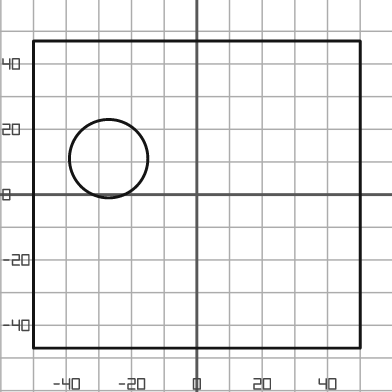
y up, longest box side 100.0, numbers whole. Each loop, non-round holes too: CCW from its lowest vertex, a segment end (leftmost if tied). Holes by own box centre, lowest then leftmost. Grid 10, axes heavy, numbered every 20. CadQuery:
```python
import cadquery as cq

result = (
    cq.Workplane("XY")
    .moveTo(-50.0, -47.0)
    .lineTo(50.0, -47.0)
    .lineTo(50.0, 47.0)
    .lineTo(-50.0, 47.0)
    .close()
    .moveTo(-27.0, 11.0)
    .circle(12.0)
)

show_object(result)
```